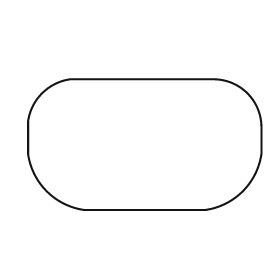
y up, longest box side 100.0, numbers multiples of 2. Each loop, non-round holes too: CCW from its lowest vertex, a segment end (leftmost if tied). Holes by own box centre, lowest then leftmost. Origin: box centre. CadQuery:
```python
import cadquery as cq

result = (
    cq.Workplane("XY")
    .moveTo(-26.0, -28.0)
    .lineTo(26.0, -28.0)
    .threePointArc((42.0, -20.0), (50.0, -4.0))
    .lineTo(50.0, 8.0)
    .threePointArc((44.0, 22.0), (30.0, 28.0))
    .lineTo(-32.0, 28.0)
    .threePointArc((-44.0, 22.0), (-50.0, 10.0))
    .lineTo(-50.0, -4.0)
    .threePointArc((-42.0, -20.0), (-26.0, -28.0))
    .close()
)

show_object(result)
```